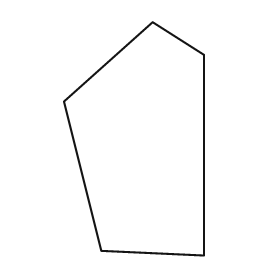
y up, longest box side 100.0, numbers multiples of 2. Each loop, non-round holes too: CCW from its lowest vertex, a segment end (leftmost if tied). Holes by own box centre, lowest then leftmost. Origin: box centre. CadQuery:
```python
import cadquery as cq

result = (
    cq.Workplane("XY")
    .moveTo(30.0, -50.0)
    .lineTo(30.0, 36.0)
    .lineTo(8.0, 50.0)
    .lineTo(-30.0, 16.0)
    .lineTo(-14.0, -48.0)
    .close()
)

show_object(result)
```